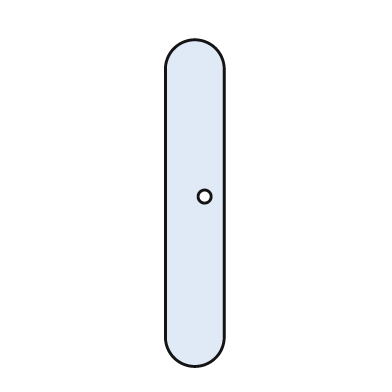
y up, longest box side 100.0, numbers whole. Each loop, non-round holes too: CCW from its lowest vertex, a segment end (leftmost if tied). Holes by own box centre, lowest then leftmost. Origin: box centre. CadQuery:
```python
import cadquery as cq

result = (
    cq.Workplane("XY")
    .moveTo(-9.0, -41.0)
    .threePointArc((0.0, -50.0), (9.0, -41.0))
    .lineTo(9.0, 41.0)
    .threePointArc((0.0, 50.0), (-9.0, 41.0))
    .close()
    .moveTo(3.0, 2.0)
    .circle(2.0)
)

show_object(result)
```